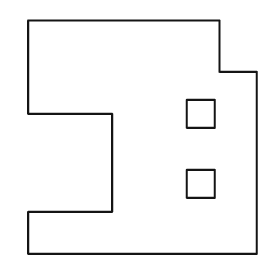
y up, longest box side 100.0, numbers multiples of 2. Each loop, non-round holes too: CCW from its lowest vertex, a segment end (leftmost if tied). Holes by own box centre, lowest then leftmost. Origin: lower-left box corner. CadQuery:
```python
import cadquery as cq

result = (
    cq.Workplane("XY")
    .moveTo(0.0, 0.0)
    .lineTo(98.0, 0.0)
    .lineTo(98.0, 78.0)
    .lineTo(82.0, 78.0)
    .lineTo(82.0, 100.0)
    .lineTo(0.0, 100.0)
    .lineTo(0.0, 60.0)
    .lineTo(36.0, 60.0)
    .lineTo(36.0, 18.0)
    .lineTo(0.0, 18.0)
    .close()
    .moveTo(68.0, 24.0)
    .lineTo(80.0, 24.0)
    .lineTo(80.0, 36.0)
    .lineTo(68.0, 36.0)
    .close()
    .moveTo(68.0, 54.0)
    .lineTo(80.0, 54.0)
    .lineTo(80.0, 66.0)
    .lineTo(68.0, 66.0)
    .close()
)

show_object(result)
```